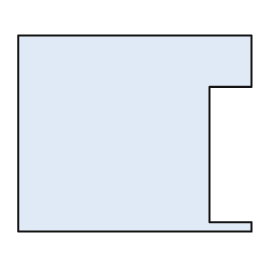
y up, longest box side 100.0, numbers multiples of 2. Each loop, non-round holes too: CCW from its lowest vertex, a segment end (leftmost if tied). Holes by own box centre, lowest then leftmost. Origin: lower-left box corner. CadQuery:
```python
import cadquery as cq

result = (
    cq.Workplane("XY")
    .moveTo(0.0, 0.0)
    .lineTo(100.0, 0.0)
    .lineTo(100.0, 4.0)
    .lineTo(82.0, 4.0)
    .lineTo(82.0, 62.0)
    .lineTo(100.0, 62.0)
    .lineTo(100.0, 84.0)
    .lineTo(0.0, 84.0)
    .close()
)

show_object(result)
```